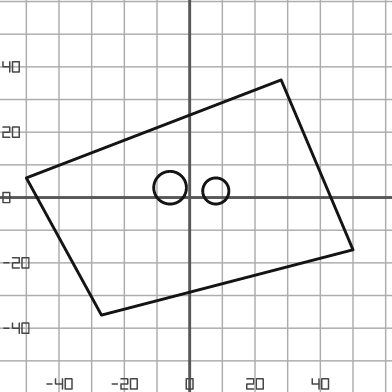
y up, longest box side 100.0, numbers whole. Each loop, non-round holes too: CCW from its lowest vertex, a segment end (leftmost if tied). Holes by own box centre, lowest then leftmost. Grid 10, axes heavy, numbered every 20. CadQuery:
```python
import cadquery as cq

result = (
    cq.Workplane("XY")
    .moveTo(-27.0, -36.0)
    .lineTo(50.0, -16.0)
    .lineTo(28.0, 36.0)
    .lineTo(-50.0, 6.0)
    .close()
    .moveTo(8.0, 2.0)
    .circle(4.0)
    .moveTo(-6.0, 3.0)
    .circle(5.0)
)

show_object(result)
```